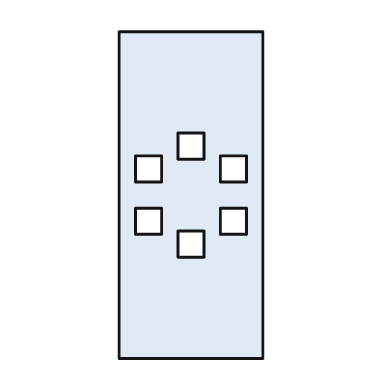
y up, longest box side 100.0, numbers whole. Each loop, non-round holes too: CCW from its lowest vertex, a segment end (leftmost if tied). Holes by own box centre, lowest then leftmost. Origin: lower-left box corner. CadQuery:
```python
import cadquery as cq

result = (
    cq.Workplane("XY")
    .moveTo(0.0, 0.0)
    .lineTo(44.0, 0.0)
    .lineTo(44.0, 100.0)
    .lineTo(0.0, 100.0)
    .close()
    .moveTo(18.0, 31.0)
    .lineTo(26.0, 31.0)
    .lineTo(26.0, 39.0)
    .lineTo(18.0, 39.0)
    .close()
    .moveTo(5.0, 38.0)
    .lineTo(13.0, 38.0)
    .lineTo(13.0, 46.0)
    .lineTo(5.0, 46.0)
    .close()
    .moveTo(31.0, 38.0)
    .lineTo(39.0, 38.0)
    .lineTo(39.0, 46.0)
    .lineTo(31.0, 46.0)
    .close()
    .moveTo(5.0, 54.0)
    .lineTo(13.0, 54.0)
    .lineTo(13.0, 62.0)
    .lineTo(5.0, 62.0)
    .close()
    .moveTo(31.0, 54.0)
    .lineTo(39.0, 54.0)
    .lineTo(39.0, 62.0)
    .lineTo(31.0, 62.0)
    .close()
    .moveTo(18.0, 61.0)
    .lineTo(26.0, 61.0)
    .lineTo(26.0, 69.0)
    .lineTo(18.0, 69.0)
    .close()
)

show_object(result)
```